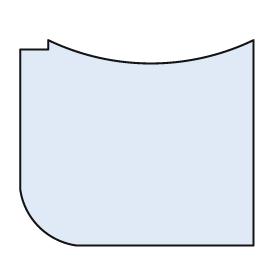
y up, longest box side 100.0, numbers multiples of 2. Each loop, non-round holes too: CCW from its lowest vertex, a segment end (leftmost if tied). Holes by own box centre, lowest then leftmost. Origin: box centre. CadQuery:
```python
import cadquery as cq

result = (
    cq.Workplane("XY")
    .moveTo(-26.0, -44.0)
    .lineTo(50.0, -44.0)
    .lineTo(50.0, 44.0)
    .threePointArc((6.0, 34.0), (-38.0, 44.0))
    .lineTo(-38.0, 40.0)
    .lineTo(-50.0, 40.0)
    .lineTo(-50.0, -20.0)
    .threePointArc((-42.0, -36.0), (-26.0, -44.0))
    .close()
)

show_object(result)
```